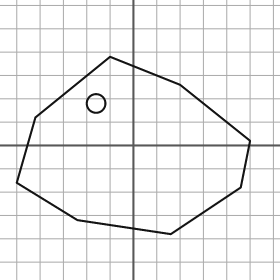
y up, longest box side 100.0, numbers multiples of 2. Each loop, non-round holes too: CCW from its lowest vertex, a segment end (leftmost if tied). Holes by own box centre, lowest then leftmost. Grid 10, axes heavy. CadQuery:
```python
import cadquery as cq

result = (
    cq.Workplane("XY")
    .moveTo(16.0, -38.0)
    .lineTo(46.0, -18.0)
    .lineTo(50.0, 2.0)
    .lineTo(20.0, 26.0)
    .lineTo(-10.0, 38.0)
    .lineTo(-42.0, 12.0)
    .lineTo(-50.0, -16.0)
    .lineTo(-24.0, -32.0)
    .close()
    .moveTo(-16.0, 18.0)
    .circle(4.0)
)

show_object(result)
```